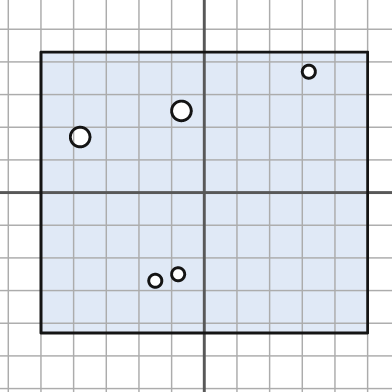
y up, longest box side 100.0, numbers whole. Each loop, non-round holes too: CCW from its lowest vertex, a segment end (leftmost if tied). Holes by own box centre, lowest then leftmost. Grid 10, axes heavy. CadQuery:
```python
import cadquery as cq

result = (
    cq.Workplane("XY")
    .moveTo(-50.0, -43.0)
    .lineTo(50.0, -43.0)
    .lineTo(50.0, 43.0)
    .lineTo(-50.0, 43.0)
    .close()
    .moveTo(-15.0, -27.0)
    .circle(2.0)
    .moveTo(-8.0, -25.0)
    .circle(2.0)
    .moveTo(-38.0, 17.0)
    .circle(3.0)
    .moveTo(-7.0, 25.0)
    .circle(3.0)
    .moveTo(32.0, 37.0)
    .circle(2.0)
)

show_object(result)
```